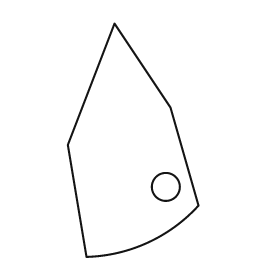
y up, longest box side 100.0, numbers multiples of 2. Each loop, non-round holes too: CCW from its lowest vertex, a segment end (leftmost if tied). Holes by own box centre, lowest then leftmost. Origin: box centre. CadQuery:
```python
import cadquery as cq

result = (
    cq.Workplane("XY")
    .moveTo(-20.0, -50.0)
    .threePointArc((6.0, -44.0), (28.0, -28.0))
    .lineTo(16.0, 14.0)
    .lineTo(-8.0, 50.0)
    .lineTo(-28.0, -2.0)
    .close()
    .moveTo(14.0, -20.0)
    .circle(6.0)
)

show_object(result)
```